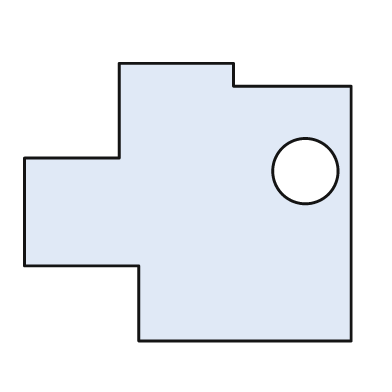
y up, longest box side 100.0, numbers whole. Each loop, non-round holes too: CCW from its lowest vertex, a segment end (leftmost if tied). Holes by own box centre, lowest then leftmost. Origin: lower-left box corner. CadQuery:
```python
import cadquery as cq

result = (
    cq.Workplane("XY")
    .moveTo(35.0, 0.0)
    .lineTo(100.0, 0.0)
    .lineTo(100.0, 78.0)
    .lineTo(64.0, 78.0)
    .lineTo(64.0, 85.0)
    .lineTo(29.0, 85.0)
    .lineTo(29.0, 56.0)
    .lineTo(0.0, 56.0)
    .lineTo(0.0, 23.0)
    .lineTo(35.0, 23.0)
    .close()
    .moveTo(86.0, 52.0)
    .circle(10.0)
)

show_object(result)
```